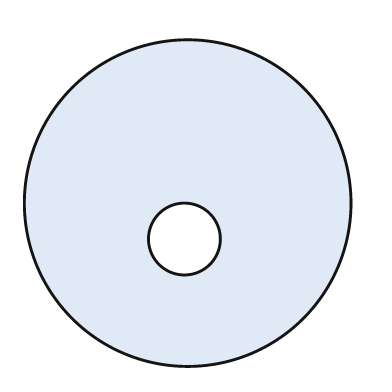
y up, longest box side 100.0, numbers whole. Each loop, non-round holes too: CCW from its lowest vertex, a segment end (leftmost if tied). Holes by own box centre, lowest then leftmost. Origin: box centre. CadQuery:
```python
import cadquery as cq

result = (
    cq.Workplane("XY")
    .moveTo(0.0, 0.0)
    .circle(50.0)
    .moveTo(-1.0, -11.0)
    .circle(11.0)
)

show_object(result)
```